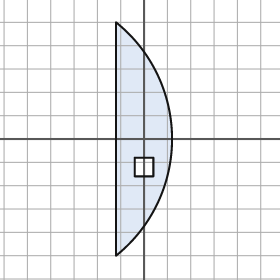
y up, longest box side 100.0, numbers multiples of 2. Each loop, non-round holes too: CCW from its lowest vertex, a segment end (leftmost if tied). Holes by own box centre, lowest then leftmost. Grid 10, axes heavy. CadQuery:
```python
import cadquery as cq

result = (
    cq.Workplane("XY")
    .moveTo(-12.0, -50.0)
    .threePointArc((12.0, 0.0), (-12.0, 50.0))
    .close()
    .moveTo(-4.0, -16.0)
    .lineTo(4.0, -16.0)
    .lineTo(4.0, -8.0)
    .lineTo(-4.0, -8.0)
    .close()
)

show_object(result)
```